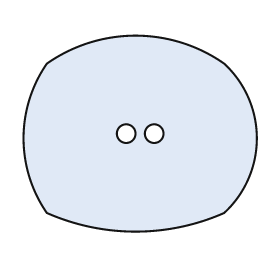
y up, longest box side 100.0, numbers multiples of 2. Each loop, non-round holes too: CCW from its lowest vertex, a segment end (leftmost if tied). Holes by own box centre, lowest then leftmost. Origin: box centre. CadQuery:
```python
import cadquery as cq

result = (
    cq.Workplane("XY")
    .moveTo(-40.0, -34.0)
    .threePointArc((-2.0, -42.0), (36.0, -34.0))
    .threePointArc((50.0, -2.0), (36.0, 30.0))
    .threePointArc((-2.0, 42.0), (-40.0, 30.0))
    .threePointArc((-50.0, -2.0), (-40.0, -34.0))
    .close()
    .moveTo(-6.0, 0.0)
    .circle(4.0)
    .moveTo(6.0, 0.0)
    .circle(4.0)
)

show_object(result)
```